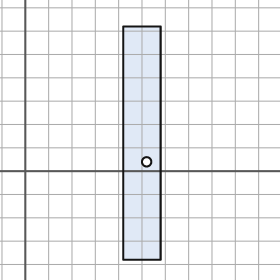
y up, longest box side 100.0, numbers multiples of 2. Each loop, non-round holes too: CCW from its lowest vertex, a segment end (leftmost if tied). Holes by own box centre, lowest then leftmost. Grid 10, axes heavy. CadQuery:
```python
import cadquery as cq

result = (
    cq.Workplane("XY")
    .moveTo(42.0, -38.0)
    .lineTo(58.0, -38.0)
    .lineTo(58.0, 62.0)
    .lineTo(42.0, 62.0)
    .close()
    .moveTo(52.0, 4.0)
    .circle(2.0)
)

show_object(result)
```